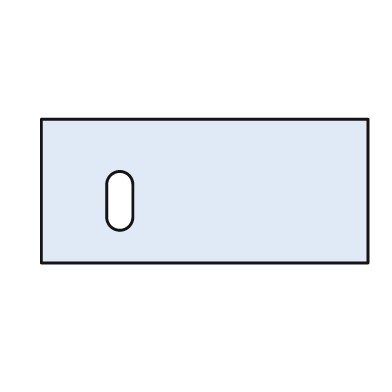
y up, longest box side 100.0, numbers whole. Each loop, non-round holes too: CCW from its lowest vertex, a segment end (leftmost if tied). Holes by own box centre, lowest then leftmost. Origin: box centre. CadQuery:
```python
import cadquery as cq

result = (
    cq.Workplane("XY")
    .moveTo(-50.0, -22.0)
    .lineTo(50.0, -22.0)
    .lineTo(50.0, 22.0)
    .lineTo(-50.0, 22.0)
    .close()
    .moveTo(-30.0, -8.0)
    .threePointArc((-26.0, -12.0), (-22.0, -8.0))
    .lineTo(-22.0, 2.0)
    .threePointArc((-26.0, 6.0), (-30.0, 2.0))
    .close()
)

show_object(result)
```